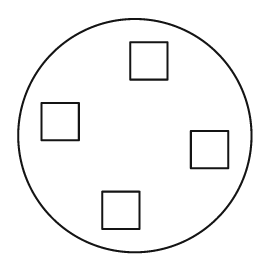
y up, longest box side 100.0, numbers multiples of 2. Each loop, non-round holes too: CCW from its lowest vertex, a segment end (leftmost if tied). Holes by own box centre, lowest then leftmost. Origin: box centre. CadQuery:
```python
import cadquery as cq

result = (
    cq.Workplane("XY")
    .moveTo(0.0, 0.0)
    .circle(50.0)
    .moveTo(-14.0, -40.0)
    .lineTo(2.0, -40.0)
    .lineTo(2.0, -24.0)
    .lineTo(-14.0, -24.0)
    .close()
    .moveTo(24.0, -14.0)
    .lineTo(40.0, -14.0)
    .lineTo(40.0, 2.0)
    .lineTo(24.0, 2.0)
    .close()
    .moveTo(-40.0, -2.0)
    .lineTo(-24.0, -2.0)
    .lineTo(-24.0, 14.0)
    .lineTo(-40.0, 14.0)
    .close()
    .moveTo(-2.0, 24.0)
    .lineTo(14.0, 24.0)
    .lineTo(14.0, 40.0)
    .lineTo(-2.0, 40.0)
    .close()
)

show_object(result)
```